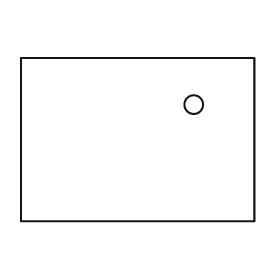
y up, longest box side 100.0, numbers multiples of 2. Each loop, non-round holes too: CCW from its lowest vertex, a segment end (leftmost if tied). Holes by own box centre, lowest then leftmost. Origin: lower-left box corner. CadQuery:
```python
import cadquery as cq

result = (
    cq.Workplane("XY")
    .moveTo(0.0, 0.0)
    .lineTo(100.0, 0.0)
    .lineTo(100.0, 70.0)
    .lineTo(0.0, 70.0)
    .close()
    .moveTo(74.0, 50.0)
    .circle(4.0)
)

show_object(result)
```